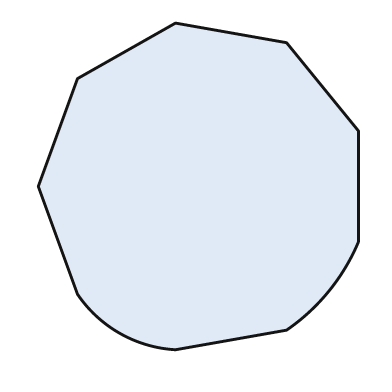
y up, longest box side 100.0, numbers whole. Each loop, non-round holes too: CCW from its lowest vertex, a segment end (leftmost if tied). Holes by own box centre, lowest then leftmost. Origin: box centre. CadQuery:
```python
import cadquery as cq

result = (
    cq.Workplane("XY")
    .moveTo(-7.0, -50.0)
    .lineTo(27.0, -44.0)
    .threePointArc((40.0, -32.0), (49.0, -17.0))
    .lineTo(49.0, 17.0)
    .lineTo(27.0, 44.0)
    .lineTo(-7.0, 50.0)
    .lineTo(-37.0, 33.0)
    .lineTo(-49.0, 0.0)
    .lineTo(-37.0, -33.0)
    .threePointArc((-24.0, -45.0), (-7.0, -50.0))
    .close()
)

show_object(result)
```